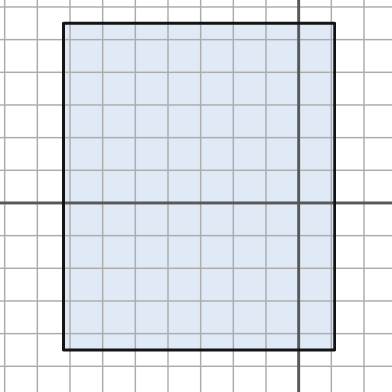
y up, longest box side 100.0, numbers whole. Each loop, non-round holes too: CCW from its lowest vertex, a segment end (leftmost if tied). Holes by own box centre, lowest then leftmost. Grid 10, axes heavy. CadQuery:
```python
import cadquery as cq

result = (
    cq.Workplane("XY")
    .moveTo(-72.0, -45.0)
    .lineTo(11.0, -45.0)
    .lineTo(11.0, 55.0)
    .lineTo(-72.0, 55.0)
    .close()
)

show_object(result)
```